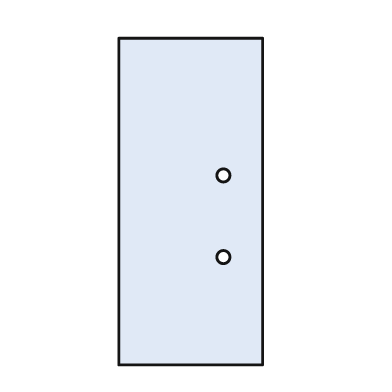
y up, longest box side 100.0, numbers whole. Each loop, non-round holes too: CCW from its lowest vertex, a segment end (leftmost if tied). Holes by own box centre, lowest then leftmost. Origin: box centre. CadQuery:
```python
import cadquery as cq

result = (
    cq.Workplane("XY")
    .moveTo(-22.0, -50.0)
    .lineTo(22.0, -50.0)
    .lineTo(22.0, 50.0)
    .lineTo(-22.0, 50.0)
    .close()
    .moveTo(10.0, -17.0)
    .circle(2.0)
    .moveTo(10.0, 8.0)
    .circle(2.0)
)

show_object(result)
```